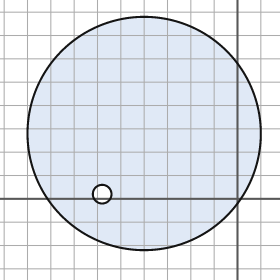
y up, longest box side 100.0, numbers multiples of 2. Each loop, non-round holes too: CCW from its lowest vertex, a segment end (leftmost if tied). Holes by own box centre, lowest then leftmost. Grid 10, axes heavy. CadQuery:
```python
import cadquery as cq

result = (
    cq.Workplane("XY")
    .moveTo(-40.0, 28.0)
    .circle(50.0)
    .moveTo(-58.0, 2.0)
    .circle(4.0)
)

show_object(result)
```